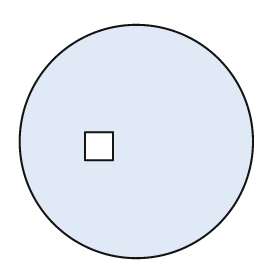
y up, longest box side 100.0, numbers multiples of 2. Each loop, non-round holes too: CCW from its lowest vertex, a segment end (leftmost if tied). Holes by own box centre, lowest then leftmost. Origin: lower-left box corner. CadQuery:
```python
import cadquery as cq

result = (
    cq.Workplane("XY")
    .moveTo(50.0, 50.0)
    .circle(50.0)
    .moveTo(28.0, 42.0)
    .lineTo(40.0, 42.0)
    .lineTo(40.0, 54.0)
    .lineTo(28.0, 54.0)
    .close()
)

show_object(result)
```